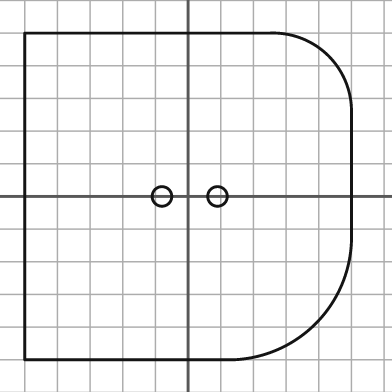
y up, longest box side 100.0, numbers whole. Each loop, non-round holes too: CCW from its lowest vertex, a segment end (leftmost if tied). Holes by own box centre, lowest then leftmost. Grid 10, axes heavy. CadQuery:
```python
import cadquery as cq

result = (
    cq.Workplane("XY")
    .moveTo(-50.0, -50.0)
    .lineTo(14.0, -50.0)
    .threePointArc((39.0, -39.0), (50.0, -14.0))
    .lineTo(50.0, 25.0)
    .threePointArc((43.0, 43.0), (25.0, 50.0))
    .lineTo(-50.0, 50.0)
    .close()
    .moveTo(-8.0, 0.0)
    .circle(3.0)
    .moveTo(9.0, 0.0)
    .circle(3.0)
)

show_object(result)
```